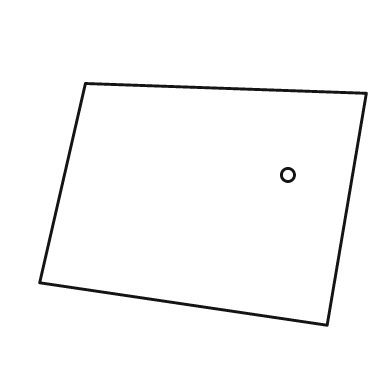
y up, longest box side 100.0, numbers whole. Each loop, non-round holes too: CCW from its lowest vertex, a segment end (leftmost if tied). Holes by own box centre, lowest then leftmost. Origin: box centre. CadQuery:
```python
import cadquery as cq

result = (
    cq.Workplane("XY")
    .moveTo(38.0, -37.0)
    .lineTo(50.0, 34.0)
    .lineTo(-36.0, 37.0)
    .lineTo(-50.0, -24.0)
    .close()
    .moveTo(26.0, 9.0)
    .circle(2.0)
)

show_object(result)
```